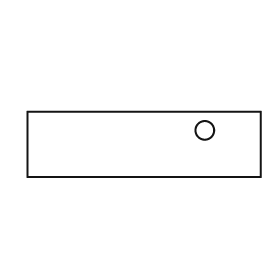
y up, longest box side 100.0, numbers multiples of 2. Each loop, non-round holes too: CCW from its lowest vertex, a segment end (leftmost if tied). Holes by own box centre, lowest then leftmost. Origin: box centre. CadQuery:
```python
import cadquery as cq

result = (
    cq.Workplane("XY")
    .moveTo(-50.0, -14.0)
    .lineTo(50.0, -14.0)
    .lineTo(50.0, 14.0)
    .lineTo(-50.0, 14.0)
    .close()
    .moveTo(26.0, 6.0)
    .circle(4.0)
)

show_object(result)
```